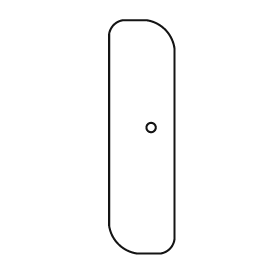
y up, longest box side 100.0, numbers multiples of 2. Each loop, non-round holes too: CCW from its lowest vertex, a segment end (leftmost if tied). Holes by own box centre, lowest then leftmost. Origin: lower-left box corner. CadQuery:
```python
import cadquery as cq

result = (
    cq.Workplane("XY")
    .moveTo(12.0, 0.0)
    .lineTo(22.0, 0.0)
    .threePointArc((26.0, 2.0), (28.0, 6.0))
    .lineTo(28.0, 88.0)
    .threePointArc((24.0, 96.0), (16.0, 100.0))
    .lineTo(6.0, 100.0)
    .threePointArc((2.0, 98.0), (0.0, 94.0))
    .lineTo(0.0, 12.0)
    .threePointArc((4.0, 4.0), (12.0, 0.0))
    .close()
    .moveTo(18.0, 54.0)
    .circle(2.0)
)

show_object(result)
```